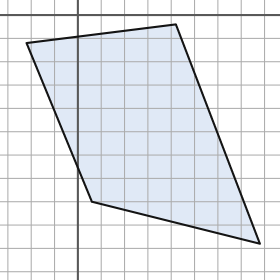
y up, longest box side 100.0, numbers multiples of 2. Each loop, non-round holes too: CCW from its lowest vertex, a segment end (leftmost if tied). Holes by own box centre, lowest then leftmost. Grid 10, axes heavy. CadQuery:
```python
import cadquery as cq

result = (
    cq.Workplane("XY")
    .moveTo(78.0, -98.0)
    .lineTo(42.0, -4.0)
    .lineTo(-22.0, -12.0)
    .lineTo(6.0, -80.0)
    .close()
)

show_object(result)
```